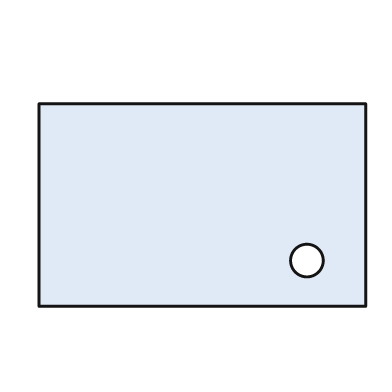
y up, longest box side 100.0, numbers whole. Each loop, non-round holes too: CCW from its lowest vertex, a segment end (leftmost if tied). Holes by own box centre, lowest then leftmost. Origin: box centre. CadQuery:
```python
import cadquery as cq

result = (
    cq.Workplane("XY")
    .moveTo(-50.0, -31.0)
    .lineTo(50.0, -31.0)
    .lineTo(50.0, 31.0)
    .lineTo(-50.0, 31.0)
    .close()
    .moveTo(32.0, -17.0)
    .circle(5.0)
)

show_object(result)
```